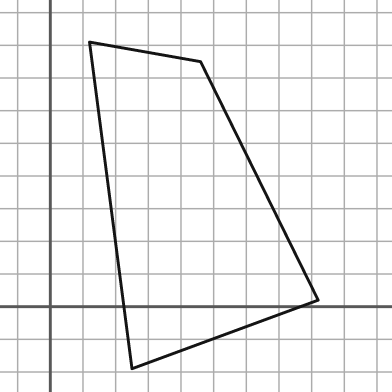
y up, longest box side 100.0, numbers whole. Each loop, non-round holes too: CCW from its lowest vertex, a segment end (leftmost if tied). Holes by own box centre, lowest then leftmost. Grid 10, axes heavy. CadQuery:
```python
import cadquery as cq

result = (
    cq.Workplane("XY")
    .moveTo(25.0, -19.0)
    .lineTo(82.0, 2.0)
    .lineTo(46.0, 75.0)
    .lineTo(12.0, 81.0)
    .close()
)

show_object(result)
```